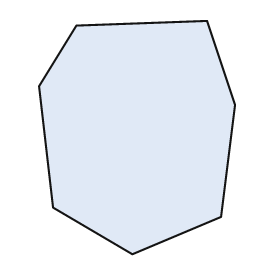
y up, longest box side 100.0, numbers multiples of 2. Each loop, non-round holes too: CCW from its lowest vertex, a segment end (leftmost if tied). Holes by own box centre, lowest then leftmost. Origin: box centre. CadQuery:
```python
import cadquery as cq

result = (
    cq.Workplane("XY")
    .moveTo(-2.0, -50.0)
    .lineTo(36.0, -34.0)
    .lineTo(42.0, 14.0)
    .lineTo(30.0, 50.0)
    .lineTo(-26.0, 48.0)
    .lineTo(-42.0, 22.0)
    .lineTo(-36.0, -30.0)
    .close()
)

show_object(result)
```